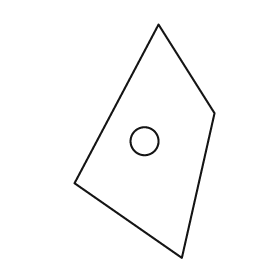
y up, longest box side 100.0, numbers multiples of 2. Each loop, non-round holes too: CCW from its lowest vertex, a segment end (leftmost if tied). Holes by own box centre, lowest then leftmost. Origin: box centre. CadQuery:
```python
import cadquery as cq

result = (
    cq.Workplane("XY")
    .moveTo(16.0, -50.0)
    .lineTo(30.0, 12.0)
    .lineTo(6.0, 50.0)
    .lineTo(-30.0, -18.0)
    .close()
    .moveTo(0.0, 0.0)
    .circle(6.0)
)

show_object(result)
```